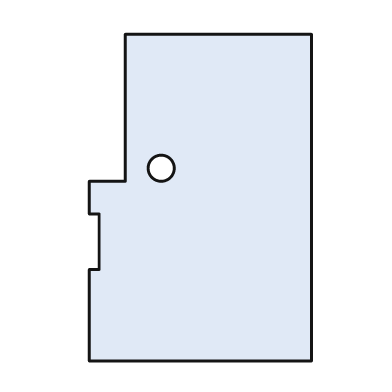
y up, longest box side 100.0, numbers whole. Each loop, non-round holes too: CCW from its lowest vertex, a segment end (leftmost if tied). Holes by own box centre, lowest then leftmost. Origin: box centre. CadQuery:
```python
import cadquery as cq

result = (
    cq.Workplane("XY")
    .moveTo(-34.0, -50.0)
    .lineTo(34.0, -50.0)
    .lineTo(34.0, 50.0)
    .lineTo(-23.0, 50.0)
    .lineTo(-23.0, 5.0)
    .lineTo(-34.0, 5.0)
    .lineTo(-34.0, -5.0)
    .lineTo(-31.0, -5.0)
    .lineTo(-31.0, -22.0)
    .lineTo(-34.0, -22.0)
    .close()
    .moveTo(-12.0, 9.0)
    .circle(4.0)
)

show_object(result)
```